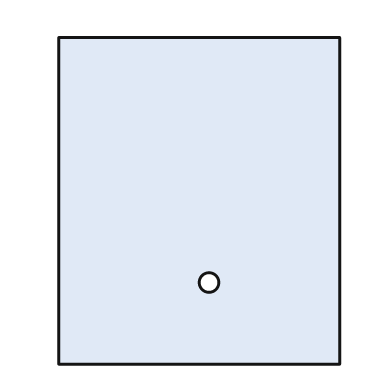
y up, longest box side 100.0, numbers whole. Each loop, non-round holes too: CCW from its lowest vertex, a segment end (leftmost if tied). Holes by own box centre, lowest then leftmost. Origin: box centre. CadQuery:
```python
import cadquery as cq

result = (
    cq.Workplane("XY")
    .moveTo(-43.0, -50.0)
    .lineTo(43.0, -50.0)
    .lineTo(43.0, 50.0)
    .lineTo(-43.0, 50.0)
    .close()
    .moveTo(3.0, -25.0)
    .circle(3.0)
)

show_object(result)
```